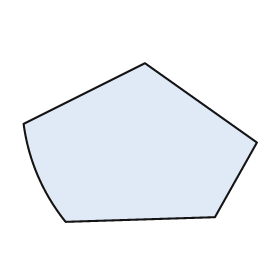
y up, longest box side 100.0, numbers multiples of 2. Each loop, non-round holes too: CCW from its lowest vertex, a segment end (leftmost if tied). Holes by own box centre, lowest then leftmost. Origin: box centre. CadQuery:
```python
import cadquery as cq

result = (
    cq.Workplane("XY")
    .moveTo(-32.0, -34.0)
    .lineTo(32.0, -32.0)
    .lineTo(50.0, 0.0)
    .lineTo(2.0, 34.0)
    .lineTo(-50.0, 8.0)
    .threePointArc((-44.0, -14.0), (-32.0, -34.0))
    .close()
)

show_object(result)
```